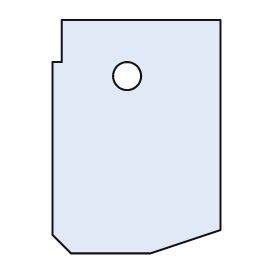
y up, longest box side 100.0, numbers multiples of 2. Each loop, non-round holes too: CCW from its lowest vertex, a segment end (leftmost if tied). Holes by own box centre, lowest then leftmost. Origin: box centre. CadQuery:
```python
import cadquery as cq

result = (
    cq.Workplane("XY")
    .moveTo(-28.0, -50.0)
    .lineTo(6.0, -50.0)
    .lineTo(36.0, -40.0)
    .lineTo(36.0, 50.0)
    .lineTo(-32.0, 50.0)
    .lineTo(-32.0, 32.0)
    .lineTo(-36.0, 32.0)
    .lineTo(-36.0, -42.0)
    .close()
    .moveTo(-4.0, 26.0)
    .circle(6.0)
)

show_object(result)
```